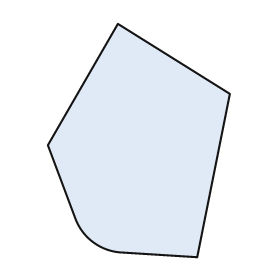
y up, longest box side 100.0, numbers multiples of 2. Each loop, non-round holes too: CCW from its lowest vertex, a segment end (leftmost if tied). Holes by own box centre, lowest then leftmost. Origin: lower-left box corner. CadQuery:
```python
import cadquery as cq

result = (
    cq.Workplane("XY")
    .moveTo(64.0, 0.0)
    .lineTo(78.0, 70.0)
    .lineTo(30.0, 100.0)
    .lineTo(0.0, 48.0)
    .lineTo(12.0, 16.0)
    .threePointArc((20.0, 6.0), (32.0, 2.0))
    .close()
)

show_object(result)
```